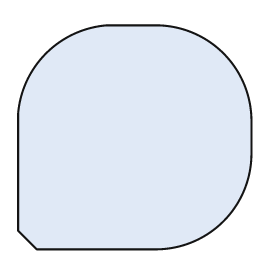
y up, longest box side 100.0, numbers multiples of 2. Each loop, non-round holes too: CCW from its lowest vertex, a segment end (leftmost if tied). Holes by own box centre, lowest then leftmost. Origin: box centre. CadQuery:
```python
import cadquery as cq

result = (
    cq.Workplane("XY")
    .moveTo(-42.0, -48.0)
    .lineTo(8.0, -48.0)
    .threePointArc((38.0, -36.0), (50.0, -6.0))
    .lineTo(50.0, 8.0)
    .threePointArc((38.0, 36.0), (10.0, 48.0))
    .lineTo(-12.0, 48.0)
    .threePointArc((-38.0, 36.0), (-50.0, 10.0))
    .lineTo(-50.0, -40.0)
    .close()
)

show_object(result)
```